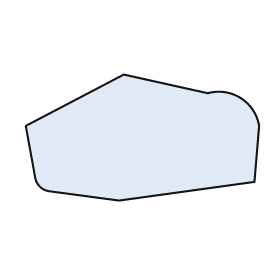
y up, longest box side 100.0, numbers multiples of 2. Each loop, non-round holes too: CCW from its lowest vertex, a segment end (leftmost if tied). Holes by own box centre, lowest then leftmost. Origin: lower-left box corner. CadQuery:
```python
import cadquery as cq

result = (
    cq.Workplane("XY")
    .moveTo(40.0, 0.0)
    .lineTo(98.0, 8.0)
    .lineTo(100.0, 32.0)
    .threePointArc((92.0, 44.0), (78.0, 46.0))
    .lineTo(42.0, 54.0)
    .lineTo(0.0, 32.0)
    .lineTo(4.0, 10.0)
    .threePointArc((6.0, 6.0), (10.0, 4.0))
    .close()
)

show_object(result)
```